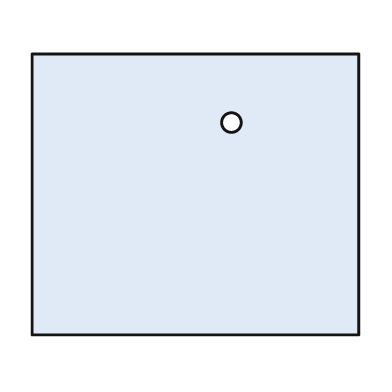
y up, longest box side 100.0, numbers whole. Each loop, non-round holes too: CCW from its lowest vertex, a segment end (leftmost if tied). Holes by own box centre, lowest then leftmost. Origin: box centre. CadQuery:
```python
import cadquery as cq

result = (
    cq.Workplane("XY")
    .moveTo(-50.0, -43.0)
    .lineTo(50.0, -43.0)
    .lineTo(50.0, 43.0)
    .lineTo(-50.0, 43.0)
    .close()
    .moveTo(11.0, 22.0)
    .circle(3.0)
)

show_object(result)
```